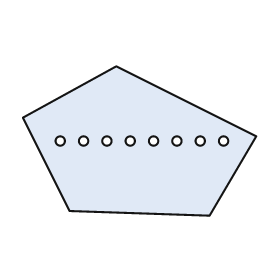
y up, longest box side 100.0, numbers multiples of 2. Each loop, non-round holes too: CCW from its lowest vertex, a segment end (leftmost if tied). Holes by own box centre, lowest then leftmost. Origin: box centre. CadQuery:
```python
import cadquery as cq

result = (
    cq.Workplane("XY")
    .moveTo(30.0, -32.0)
    .lineTo(50.0, 2.0)
    .lineTo(-10.0, 32.0)
    .lineTo(-50.0, 10.0)
    .lineTo(-30.0, -30.0)
    .close()
    .moveTo(-34.0, 0.0)
    .circle(2.0)
    .moveTo(-24.0, 0.0)
    .circle(2.0)
    .moveTo(-14.0, 0.0)
    .circle(2.0)
    .moveTo(-4.0, 0.0)
    .circle(2.0)
    .moveTo(6.0, 0.0)
    .circle(2.0)
    .moveTo(16.0, 0.0)
    .circle(2.0)
    .moveTo(26.0, 0.0)
    .circle(2.0)
    .moveTo(36.0, 0.0)
    .circle(2.0)
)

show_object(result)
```